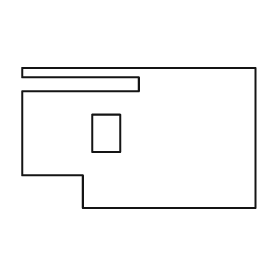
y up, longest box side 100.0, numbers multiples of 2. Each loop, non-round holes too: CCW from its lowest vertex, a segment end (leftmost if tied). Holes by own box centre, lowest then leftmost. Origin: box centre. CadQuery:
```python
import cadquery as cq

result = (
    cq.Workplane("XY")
    .moveTo(-24.0, -30.0)
    .lineTo(50.0, -30.0)
    .lineTo(50.0, 30.0)
    .lineTo(-50.0, 30.0)
    .lineTo(-50.0, 26.0)
    .lineTo(0.0, 26.0)
    .lineTo(0.0, 20.0)
    .lineTo(-50.0, 20.0)
    .lineTo(-50.0, -16.0)
    .lineTo(-24.0, -16.0)
    .close()
    .moveTo(-20.0, -6.0)
    .lineTo(-8.0, -6.0)
    .lineTo(-8.0, 10.0)
    .lineTo(-20.0, 10.0)
    .close()
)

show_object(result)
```